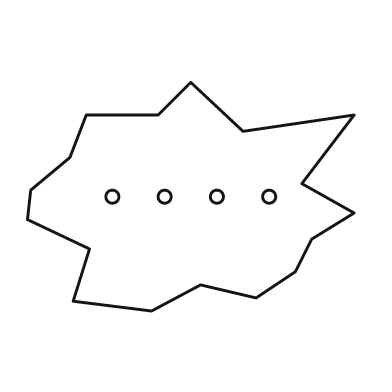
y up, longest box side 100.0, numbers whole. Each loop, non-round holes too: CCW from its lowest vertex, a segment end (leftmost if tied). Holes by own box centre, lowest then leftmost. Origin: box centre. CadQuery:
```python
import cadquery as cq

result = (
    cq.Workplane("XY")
    .moveTo(-12.0, -35.0)
    .lineTo(3.0, -27.0)
    .lineTo(20.0, -31.0)
    .lineTo(32.0, -23.0)
    .lineTo(37.0, -13.0)
    .lineTo(50.0, -5.0)
    .lineTo(34.0, 4.0)
    .lineTo(50.0, 25.0)
    .lineTo(16.0, 20.0)
    .lineTo(0.0, 35.0)
    .lineTo(-10.0, 25.0)
    .lineTo(-32.0, 25.0)
    .lineTo(-37.0, 12.0)
    .lineTo(-49.0, 2.0)
    .lineTo(-50.0, -7.0)
    .lineTo(-31.0, -16.0)
    .lineTo(-36.0, -32.0)
    .close()
    .moveTo(-24.0, 0.0)
    .circle(2.0)
    .moveTo(-8.0, 0.0)
    .circle(2.0)
    .moveTo(8.0, 0.0)
    .circle(2.0)
    .moveTo(24.0, 0.0)
    .circle(2.0)
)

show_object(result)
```